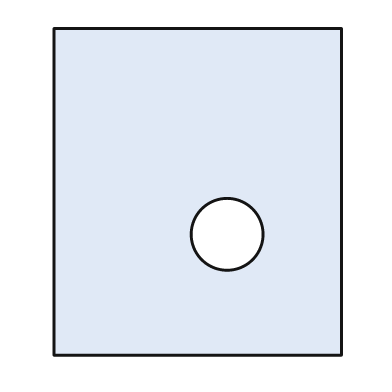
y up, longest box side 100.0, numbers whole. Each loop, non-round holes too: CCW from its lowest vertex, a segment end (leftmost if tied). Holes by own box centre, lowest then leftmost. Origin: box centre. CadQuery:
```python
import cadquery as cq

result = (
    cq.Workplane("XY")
    .moveTo(-44.0, -50.0)
    .lineTo(44.0, -50.0)
    .lineTo(44.0, 50.0)
    .lineTo(-44.0, 50.0)
    .close()
    .moveTo(9.0, -13.0)
    .circle(11.0)
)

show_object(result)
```